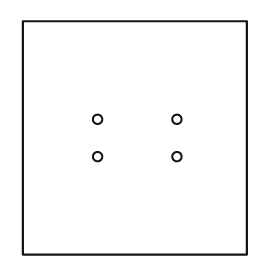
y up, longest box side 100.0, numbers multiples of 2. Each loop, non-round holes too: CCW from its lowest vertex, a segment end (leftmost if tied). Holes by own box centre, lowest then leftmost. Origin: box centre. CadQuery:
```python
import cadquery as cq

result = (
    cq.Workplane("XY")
    .moveTo(-48.0, -50.0)
    .lineTo(48.0, -50.0)
    .lineTo(48.0, 50.0)
    .lineTo(-48.0, 50.0)
    .close()
    .moveTo(-16.0, -8.0)
    .circle(2.0)
    .moveTo(18.0, -8.0)
    .circle(2.0)
    .moveTo(-16.0, 8.0)
    .circle(2.0)
    .moveTo(18.0, 8.0)
    .circle(2.0)
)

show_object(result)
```